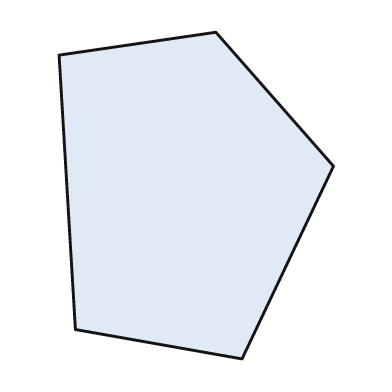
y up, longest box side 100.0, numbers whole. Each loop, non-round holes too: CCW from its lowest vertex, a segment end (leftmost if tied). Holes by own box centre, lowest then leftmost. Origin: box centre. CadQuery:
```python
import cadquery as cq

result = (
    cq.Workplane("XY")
    .moveTo(14.0, -50.0)
    .lineTo(42.0, 9.0)
    .lineTo(6.0, 50.0)
    .lineTo(-42.0, 43.0)
    .lineTo(-37.0, -41.0)
    .close()
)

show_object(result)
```